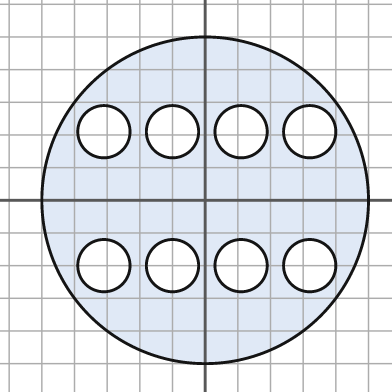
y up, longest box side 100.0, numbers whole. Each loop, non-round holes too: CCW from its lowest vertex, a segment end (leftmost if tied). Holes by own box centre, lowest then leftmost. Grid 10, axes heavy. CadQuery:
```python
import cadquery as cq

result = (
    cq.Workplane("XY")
    .moveTo(0.0, 0.0)
    .circle(50.0)
    .moveTo(-31.0, -20.0)
    .circle(8.0)
    .moveTo(-10.0, -20.0)
    .circle(8.0)
    .moveTo(11.0, -20.0)
    .circle(8.0)
    .moveTo(32.0, -20.0)
    .circle(8.0)
    .moveTo(-31.0, 21.0)
    .circle(8.0)
    .moveTo(-10.0, 21.0)
    .circle(8.0)
    .moveTo(11.0, 21.0)
    .circle(8.0)
    .moveTo(32.0, 21.0)
    .circle(8.0)
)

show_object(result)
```